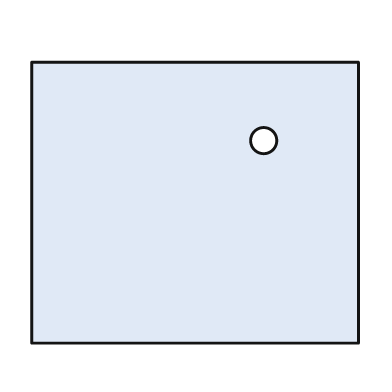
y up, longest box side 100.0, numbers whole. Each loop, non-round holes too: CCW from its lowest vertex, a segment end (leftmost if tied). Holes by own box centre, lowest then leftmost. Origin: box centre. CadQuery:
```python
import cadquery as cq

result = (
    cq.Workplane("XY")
    .moveTo(-50.0, -43.0)
    .lineTo(50.0, -43.0)
    .lineTo(50.0, 43.0)
    .lineTo(-50.0, 43.0)
    .close()
    .moveTo(21.0, 19.0)
    .circle(4.0)
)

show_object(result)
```